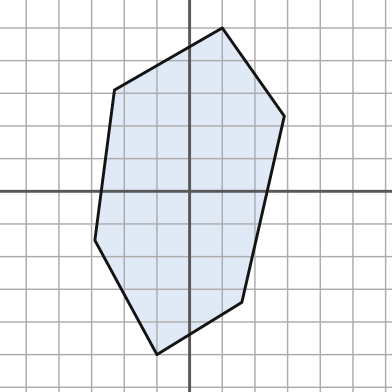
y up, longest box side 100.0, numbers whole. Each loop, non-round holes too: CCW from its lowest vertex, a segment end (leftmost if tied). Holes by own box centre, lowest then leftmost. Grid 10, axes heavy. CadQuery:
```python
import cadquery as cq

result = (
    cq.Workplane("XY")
    .moveTo(-10.0, -50.0)
    .lineTo(16.0, -34.0)
    .lineTo(29.0, 23.0)
    .lineTo(10.0, 50.0)
    .lineTo(-23.0, 31.0)
    .lineTo(-29.0, -15.0)
    .close()
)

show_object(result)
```